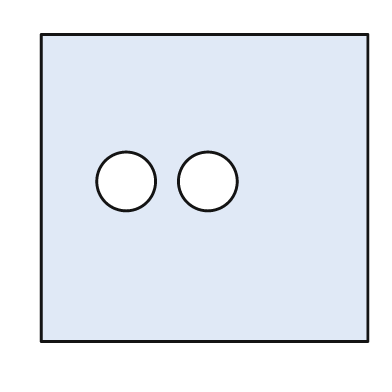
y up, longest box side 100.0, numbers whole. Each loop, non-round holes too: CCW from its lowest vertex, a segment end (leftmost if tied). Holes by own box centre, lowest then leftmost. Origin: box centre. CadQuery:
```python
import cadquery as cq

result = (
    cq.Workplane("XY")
    .moveTo(-50.0, -47.0)
    .lineTo(50.0, -47.0)
    .lineTo(50.0, 47.0)
    .lineTo(-50.0, 47.0)
    .close()
    .moveTo(-24.0, 2.0)
    .circle(9.0)
    .moveTo(1.0, 2.0)
    .circle(9.0)
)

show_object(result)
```